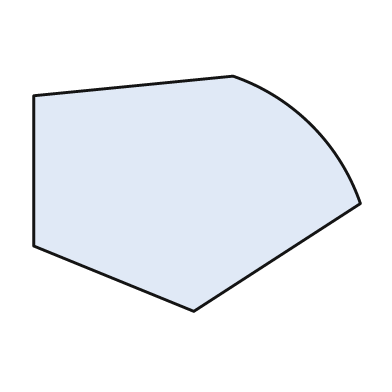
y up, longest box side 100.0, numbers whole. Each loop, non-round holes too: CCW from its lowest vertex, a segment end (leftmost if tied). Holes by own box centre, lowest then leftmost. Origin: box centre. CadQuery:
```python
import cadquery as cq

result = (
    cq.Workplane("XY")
    .moveTo(-1.0, -36.0)
    .lineTo(50.0, -3.0)
    .threePointArc((35.0, 21.0), (11.0, 36.0))
    .lineTo(-50.0, 30.0)
    .lineTo(-50.0, -16.0)
    .close()
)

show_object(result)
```